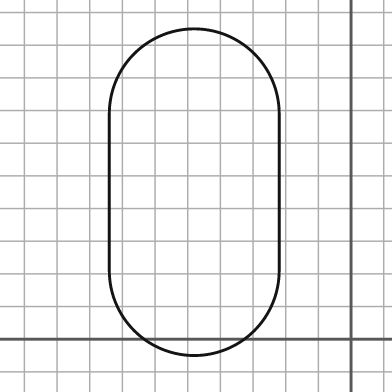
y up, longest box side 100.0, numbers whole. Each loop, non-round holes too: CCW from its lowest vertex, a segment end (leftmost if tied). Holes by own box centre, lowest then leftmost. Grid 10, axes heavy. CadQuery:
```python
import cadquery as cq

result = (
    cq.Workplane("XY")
    .moveTo(-74.0, 21.0)
    .threePointArc((-48.0, -5.0), (-22.0, 21.0))
    .lineTo(-22.0, 69.0)
    .threePointArc((-48.0, 95.0), (-74.0, 69.0))
    .close()
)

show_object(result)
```